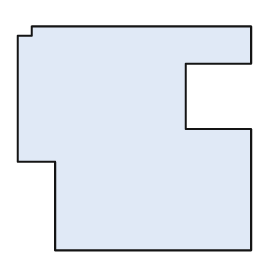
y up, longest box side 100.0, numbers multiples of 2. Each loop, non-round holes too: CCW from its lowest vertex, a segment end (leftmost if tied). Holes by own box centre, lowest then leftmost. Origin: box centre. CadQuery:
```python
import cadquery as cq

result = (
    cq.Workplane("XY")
    .moveTo(-34.0, -48.0)
    .lineTo(50.0, -48.0)
    .lineTo(50.0, 4.0)
    .lineTo(22.0, 4.0)
    .lineTo(22.0, 32.0)
    .lineTo(50.0, 32.0)
    .lineTo(50.0, 48.0)
    .lineTo(-44.0, 48.0)
    .lineTo(-44.0, 44.0)
    .lineTo(-50.0, 44.0)
    .lineTo(-50.0, -10.0)
    .lineTo(-34.0, -10.0)
    .close()
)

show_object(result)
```